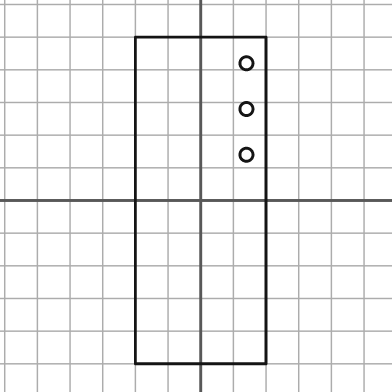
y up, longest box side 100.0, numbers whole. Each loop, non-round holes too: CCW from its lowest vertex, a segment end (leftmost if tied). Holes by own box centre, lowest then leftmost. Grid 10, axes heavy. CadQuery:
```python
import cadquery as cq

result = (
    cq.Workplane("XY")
    .moveTo(-20.0, -50.0)
    .lineTo(20.0, -50.0)
    .lineTo(20.0, 50.0)
    .lineTo(-20.0, 50.0)
    .close()
    .moveTo(14.0, 14.0)
    .circle(2.0)
    .moveTo(14.0, 28.0)
    .circle(2.0)
    .moveTo(14.0, 42.0)
    .circle(2.0)
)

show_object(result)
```